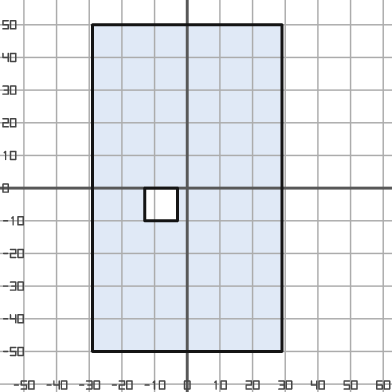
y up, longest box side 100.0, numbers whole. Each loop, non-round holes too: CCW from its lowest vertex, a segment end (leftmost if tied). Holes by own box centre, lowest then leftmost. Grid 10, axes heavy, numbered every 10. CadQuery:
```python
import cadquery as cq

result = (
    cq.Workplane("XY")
    .moveTo(-29.0, -50.0)
    .lineTo(29.0, -50.0)
    .lineTo(29.0, 50.0)
    .lineTo(-29.0, 50.0)
    .close()
    .moveTo(-13.0, -10.0)
    .lineTo(-3.0, -10.0)
    .lineTo(-3.0, 0.0)
    .lineTo(-13.0, 0.0)
    .close()
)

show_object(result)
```